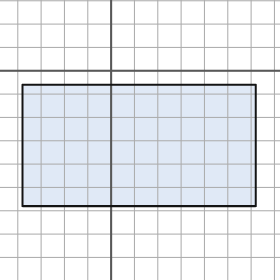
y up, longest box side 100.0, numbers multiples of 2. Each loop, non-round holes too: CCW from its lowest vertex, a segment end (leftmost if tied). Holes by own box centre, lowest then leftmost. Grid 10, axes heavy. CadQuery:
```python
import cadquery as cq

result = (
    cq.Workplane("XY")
    .moveTo(-38.0, -58.0)
    .lineTo(62.0, -58.0)
    .lineTo(62.0, -6.0)
    .lineTo(-38.0, -6.0)
    .close()
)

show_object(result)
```